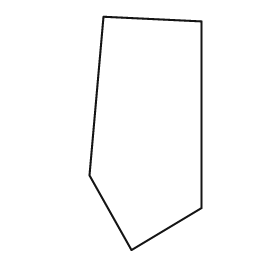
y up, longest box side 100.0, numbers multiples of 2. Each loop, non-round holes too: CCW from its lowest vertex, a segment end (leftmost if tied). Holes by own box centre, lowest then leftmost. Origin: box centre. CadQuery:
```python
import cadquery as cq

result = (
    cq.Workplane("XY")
    .moveTo(-6.0, -50.0)
    .lineTo(24.0, -32.0)
    .lineTo(24.0, 48.0)
    .lineTo(-18.0, 50.0)
    .lineTo(-24.0, -18.0)
    .close()
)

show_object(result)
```